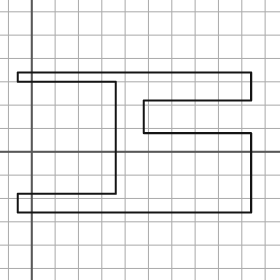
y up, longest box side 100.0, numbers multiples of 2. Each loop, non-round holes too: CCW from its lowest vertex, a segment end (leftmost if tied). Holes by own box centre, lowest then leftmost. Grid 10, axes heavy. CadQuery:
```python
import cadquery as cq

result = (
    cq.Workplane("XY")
    .moveTo(-6.0, -26.0)
    .lineTo(94.0, -26.0)
    .lineTo(94.0, 8.0)
    .lineTo(48.0, 8.0)
    .lineTo(48.0, 22.0)
    .lineTo(94.0, 22.0)
    .lineTo(94.0, 34.0)
    .lineTo(-6.0, 34.0)
    .lineTo(-6.0, 30.0)
    .lineTo(36.0, 30.0)
    .lineTo(36.0, -18.0)
    .lineTo(-6.0, -18.0)
    .close()
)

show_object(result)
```